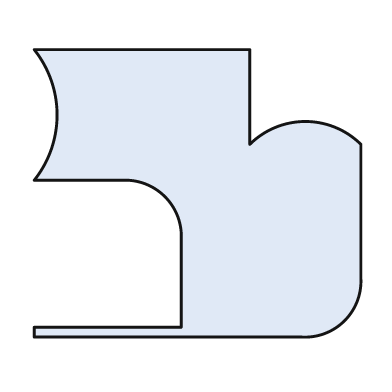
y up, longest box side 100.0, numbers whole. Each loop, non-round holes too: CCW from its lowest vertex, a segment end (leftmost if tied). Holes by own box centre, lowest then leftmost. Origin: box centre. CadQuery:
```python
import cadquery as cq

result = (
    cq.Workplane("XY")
    .moveTo(-50.0, -44.0)
    .lineTo(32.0, -44.0)
    .threePointArc((45.0, -39.0), (50.0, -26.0))
    .lineTo(50.0, 15.0)
    .threePointArc((33.0, 22.0), (16.0, 15.0))
    .lineTo(16.0, 44.0)
    .lineTo(-50.0, 44.0)
    .threePointArc((-43.0, 24.0), (-50.0, 4.0))
    .lineTo(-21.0, 4.0)
    .threePointArc((-10.0, -1.0), (-5.0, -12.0))
    .lineTo(-5.0, -41.0)
    .lineTo(-50.0, -41.0)
    .close()
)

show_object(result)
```